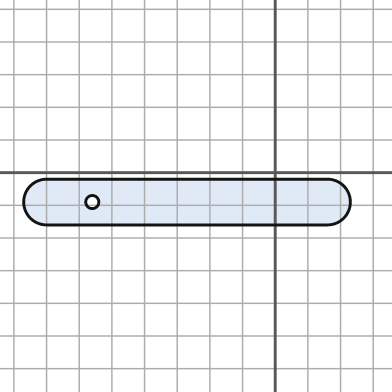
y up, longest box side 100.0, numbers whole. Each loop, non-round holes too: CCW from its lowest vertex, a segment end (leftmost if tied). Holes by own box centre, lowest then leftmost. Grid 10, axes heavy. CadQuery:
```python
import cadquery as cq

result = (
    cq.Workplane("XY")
    .moveTo(-70.0, -16.0)
    .lineTo(16.0, -16.0)
    .threePointArc((23.0, -9.0), (16.0, -2.0))
    .lineTo(-70.0, -2.0)
    .threePointArc((-77.0, -9.0), (-70.0, -16.0))
    .close()
    .moveTo(-56.0, -9.0)
    .circle(2.0)
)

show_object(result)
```